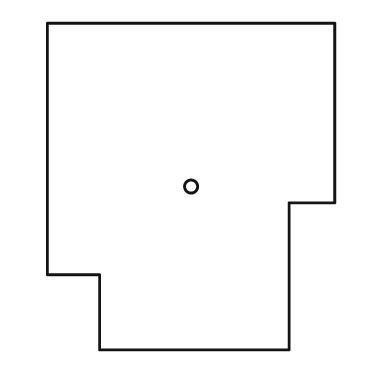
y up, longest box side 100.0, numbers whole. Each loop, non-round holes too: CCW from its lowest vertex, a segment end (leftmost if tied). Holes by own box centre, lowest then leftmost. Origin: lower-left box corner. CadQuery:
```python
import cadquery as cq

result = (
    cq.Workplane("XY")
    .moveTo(16.0, 0.0)
    .lineTo(74.0, 0.0)
    .lineTo(74.0, 45.0)
    .lineTo(88.0, 45.0)
    .lineTo(88.0, 100.0)
    .lineTo(0.0, 100.0)
    .lineTo(0.0, 23.0)
    .lineTo(16.0, 23.0)
    .close()
    .moveTo(44.0, 50.0)
    .circle(2.0)
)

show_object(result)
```